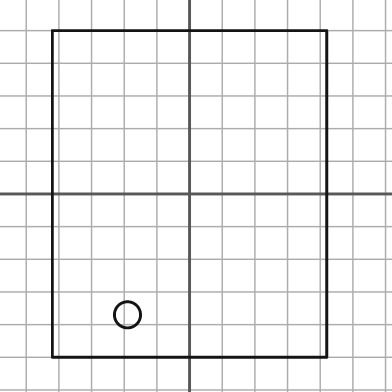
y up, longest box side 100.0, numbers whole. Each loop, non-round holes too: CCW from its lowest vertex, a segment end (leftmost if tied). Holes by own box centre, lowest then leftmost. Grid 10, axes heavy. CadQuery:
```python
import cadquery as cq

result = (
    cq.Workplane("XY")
    .moveTo(-42.0, -50.0)
    .lineTo(42.0, -50.0)
    .lineTo(42.0, 50.0)
    .lineTo(-42.0, 50.0)
    .close()
    .moveTo(-19.0, -37.0)
    .circle(4.0)
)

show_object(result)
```